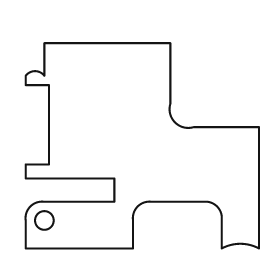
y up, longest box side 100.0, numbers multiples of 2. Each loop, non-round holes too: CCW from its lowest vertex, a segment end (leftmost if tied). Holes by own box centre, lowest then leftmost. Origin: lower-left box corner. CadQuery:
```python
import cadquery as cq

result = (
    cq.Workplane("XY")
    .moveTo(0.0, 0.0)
    .lineTo(46.0, 0.0)
    .lineTo(46.0, 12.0)
    .threePointArc((48.0, 18.0), (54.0, 20.0))
    .lineTo(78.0, 20.0)
    .threePointArc((82.0, 18.0), (84.0, 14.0))
    .lineTo(84.0, 0.0)
    .threePointArc((92.0, 2.0), (100.0, 0.0))
    .lineTo(100.0, 52.0)
    .lineTo(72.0, 52.0)
    .threePointArc((64.0, 54.0), (62.0, 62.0))
    .lineTo(62.0, 88.0)
    .lineTo(8.0, 88.0)
    .lineTo(8.0, 74.0)
    .threePointArc((4.0, 76.0), (0.0, 74.0))
    .lineTo(0.0, 70.0)
    .lineTo(10.0, 70.0)
    .lineTo(10.0, 36.0)
    .lineTo(0.0, 36.0)
    .lineTo(0.0, 30.0)
    .lineTo(38.0, 30.0)
    .lineTo(38.0, 20.0)
    .lineTo(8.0, 20.0)
    .threePointArc((2.0, 18.0), (0.0, 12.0))
    .close()
    .moveTo(8.0, 12.0)
    .circle(4.0)
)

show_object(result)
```